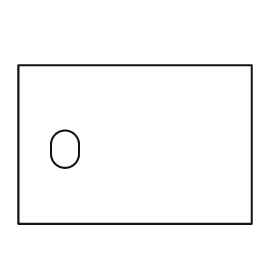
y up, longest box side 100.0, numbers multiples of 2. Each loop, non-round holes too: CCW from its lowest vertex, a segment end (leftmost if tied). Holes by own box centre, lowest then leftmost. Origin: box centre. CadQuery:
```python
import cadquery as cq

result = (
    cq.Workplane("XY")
    .moveTo(-50.0, -34.0)
    .lineTo(50.0, -34.0)
    .lineTo(50.0, 34.0)
    .lineTo(-50.0, 34.0)
    .close()
    .moveTo(-36.0, -4.0)
    .threePointArc((-30.0, -10.0), (-24.0, -4.0))
    .lineTo(-24.0, 0.0)
    .threePointArc((-30.0, 6.0), (-36.0, 0.0))
    .close()
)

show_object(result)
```